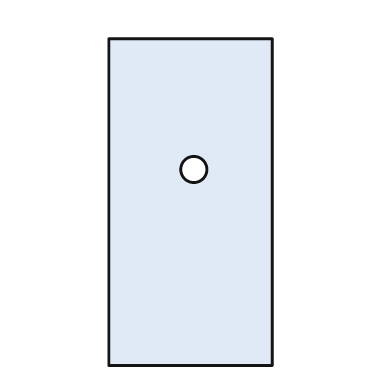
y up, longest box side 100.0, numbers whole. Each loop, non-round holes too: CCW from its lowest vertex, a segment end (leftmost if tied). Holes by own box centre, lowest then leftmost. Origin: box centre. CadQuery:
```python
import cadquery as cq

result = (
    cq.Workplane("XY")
    .moveTo(-25.0, -50.0)
    .lineTo(25.0, -50.0)
    .lineTo(25.0, 50.0)
    .lineTo(-25.0, 50.0)
    .close()
    .moveTo(1.0, 10.0)
    .circle(4.0)
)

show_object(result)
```